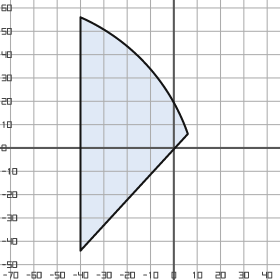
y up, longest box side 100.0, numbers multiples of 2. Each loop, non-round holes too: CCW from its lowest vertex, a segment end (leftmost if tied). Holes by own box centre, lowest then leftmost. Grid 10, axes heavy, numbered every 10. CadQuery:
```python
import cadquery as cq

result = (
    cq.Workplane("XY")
    .moveTo(-40.0, -44.0)
    .lineTo(6.0, 6.0)
    .threePointArc((-12.0, 36.0), (-40.0, 56.0))
    .close()
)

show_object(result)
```